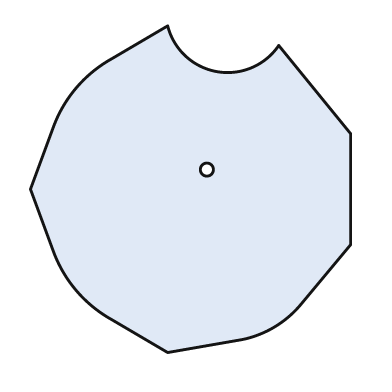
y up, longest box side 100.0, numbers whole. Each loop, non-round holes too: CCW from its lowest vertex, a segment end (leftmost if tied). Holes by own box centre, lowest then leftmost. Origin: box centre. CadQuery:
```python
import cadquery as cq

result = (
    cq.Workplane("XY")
    .moveTo(-7.0, -50.0)
    .lineTo(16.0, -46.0)
    .threePointArc((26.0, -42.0), (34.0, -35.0))
    .lineTo(49.0, -17.0)
    .lineTo(49.0, 17.0)
    .lineTo(27.0, 44.0)
    .threePointArc((8.0, 36.0), (-7.0, 50.0))
    .lineTo(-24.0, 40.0)
    .threePointArc((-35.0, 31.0), (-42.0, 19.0))
    .lineTo(-49.0, 0.0)
    .lineTo(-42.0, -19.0)
    .threePointArc((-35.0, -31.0), (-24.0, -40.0))
    .close()
    .moveTo(5.0, 6.0)
    .circle(2.0)
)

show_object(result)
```